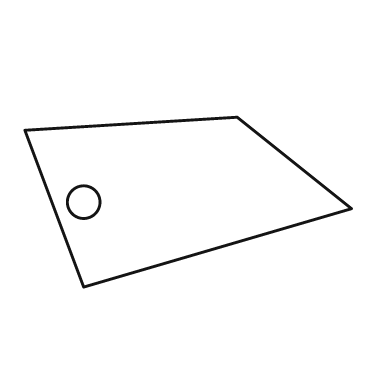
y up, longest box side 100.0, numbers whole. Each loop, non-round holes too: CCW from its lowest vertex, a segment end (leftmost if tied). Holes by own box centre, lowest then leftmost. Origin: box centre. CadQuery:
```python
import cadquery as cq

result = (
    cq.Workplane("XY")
    .moveTo(-32.0, -26.0)
    .lineTo(50.0, -2.0)
    .lineTo(15.0, 26.0)
    .lineTo(-50.0, 22.0)
    .close()
    .moveTo(-32.0, 0.0)
    .circle(5.0)
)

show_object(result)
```